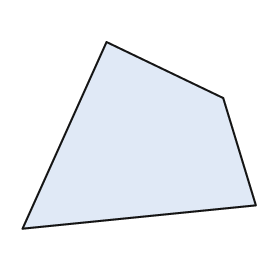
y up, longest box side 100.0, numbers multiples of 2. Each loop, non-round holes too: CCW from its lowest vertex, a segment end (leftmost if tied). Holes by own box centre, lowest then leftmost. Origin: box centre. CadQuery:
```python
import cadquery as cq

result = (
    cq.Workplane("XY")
    .moveTo(-50.0, -40.0)
    .lineTo(50.0, -30.0)
    .lineTo(36.0, 16.0)
    .lineTo(-14.0, 40.0)
    .close()
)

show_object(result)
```